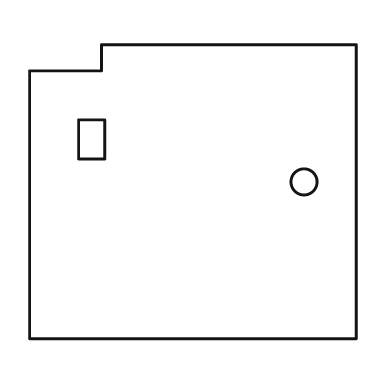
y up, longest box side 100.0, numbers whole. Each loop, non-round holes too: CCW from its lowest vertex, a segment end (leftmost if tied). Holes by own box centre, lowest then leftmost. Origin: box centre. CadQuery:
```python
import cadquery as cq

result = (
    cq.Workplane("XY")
    .moveTo(-50.0, -45.0)
    .lineTo(50.0, -45.0)
    .lineTo(50.0, 45.0)
    .lineTo(-28.0, 45.0)
    .lineTo(-28.0, 37.0)
    .lineTo(-50.0, 37.0)
    .close()
    .moveTo(34.0, 3.0)
    .circle(4.0)
    .moveTo(-35.0, 10.0)
    .lineTo(-27.0, 10.0)
    .lineTo(-27.0, 22.0)
    .lineTo(-35.0, 22.0)
    .close()
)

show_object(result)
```